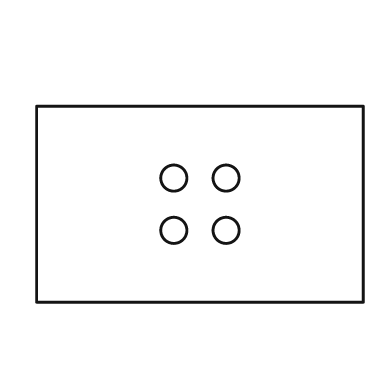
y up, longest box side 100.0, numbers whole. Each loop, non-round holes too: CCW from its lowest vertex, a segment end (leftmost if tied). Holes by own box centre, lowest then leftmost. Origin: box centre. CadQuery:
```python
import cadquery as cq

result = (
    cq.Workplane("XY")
    .moveTo(-50.0, -30.0)
    .lineTo(50.0, -30.0)
    .lineTo(50.0, 30.0)
    .lineTo(-50.0, 30.0)
    .close()
    .moveTo(-8.0, -8.0)
    .circle(4.0)
    .moveTo(8.0, -8.0)
    .circle(4.0)
    .moveTo(-8.0, 8.0)
    .circle(4.0)
    .moveTo(8.0, 8.0)
    .circle(4.0)
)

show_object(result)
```